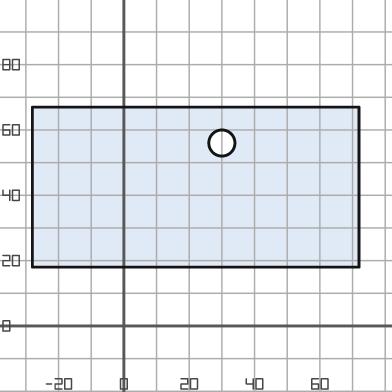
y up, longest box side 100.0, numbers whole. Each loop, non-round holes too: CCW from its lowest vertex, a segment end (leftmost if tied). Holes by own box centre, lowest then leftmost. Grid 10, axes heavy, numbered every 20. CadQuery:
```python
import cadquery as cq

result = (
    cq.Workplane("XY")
    .moveTo(-28.0, 18.0)
    .lineTo(72.0, 18.0)
    .lineTo(72.0, 67.0)
    .lineTo(-28.0, 67.0)
    .close()
    .moveTo(30.0, 56.0)
    .circle(4.0)
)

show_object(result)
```